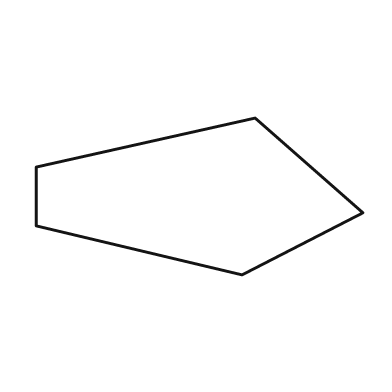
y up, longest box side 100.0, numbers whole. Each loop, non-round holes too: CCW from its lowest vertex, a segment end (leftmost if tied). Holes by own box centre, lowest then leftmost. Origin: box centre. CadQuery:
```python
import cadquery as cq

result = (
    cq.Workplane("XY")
    .moveTo(13.0, -24.0)
    .lineTo(50.0, -5.0)
    .lineTo(17.0, 24.0)
    .lineTo(-50.0, 9.0)
    .lineTo(-50.0, -9.0)
    .close()
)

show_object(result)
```